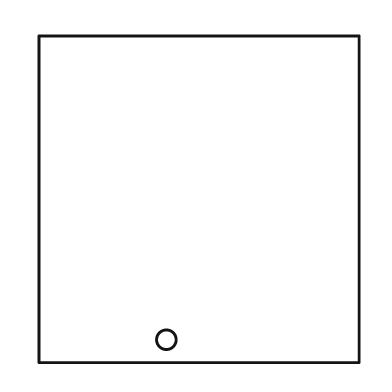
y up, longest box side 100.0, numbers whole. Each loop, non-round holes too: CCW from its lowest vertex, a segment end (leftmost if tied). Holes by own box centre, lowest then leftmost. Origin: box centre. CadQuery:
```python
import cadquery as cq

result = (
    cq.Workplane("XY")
    .moveTo(-49.0, -50.0)
    .lineTo(49.0, -50.0)
    .lineTo(49.0, 50.0)
    .lineTo(-49.0, 50.0)
    .close()
    .moveTo(-10.0, -43.0)
    .circle(3.0)
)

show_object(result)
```